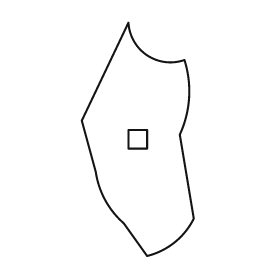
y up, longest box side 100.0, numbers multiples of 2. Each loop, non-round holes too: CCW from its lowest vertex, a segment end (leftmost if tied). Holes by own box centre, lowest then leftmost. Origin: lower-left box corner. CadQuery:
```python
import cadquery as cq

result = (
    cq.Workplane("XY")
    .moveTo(28.0, 0.0)
    .threePointArc((40.0, 6.0), (48.0, 16.0))
    .lineTo(42.0, 52.0)
    .threePointArc((46.0, 68.0), (44.0, 84.0))
    .threePointArc((28.0, 86.0), (20.0, 100.0))
    .lineTo(0.0, 58.0)
    .lineTo(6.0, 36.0)
    .threePointArc((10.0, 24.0), (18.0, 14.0))
    .close()
    .moveTo(20.0, 46.0)
    .lineTo(28.0, 46.0)
    .lineTo(28.0, 54.0)
    .lineTo(20.0, 54.0)
    .close()
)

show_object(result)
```